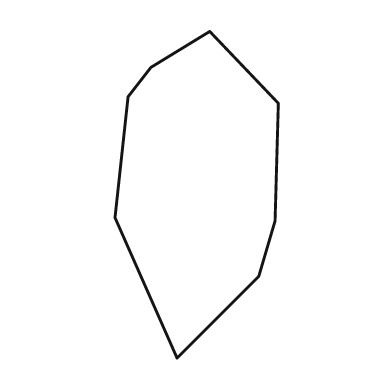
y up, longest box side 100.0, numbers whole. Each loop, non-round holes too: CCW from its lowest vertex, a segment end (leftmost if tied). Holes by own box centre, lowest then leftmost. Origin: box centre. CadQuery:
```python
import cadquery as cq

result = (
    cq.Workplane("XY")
    .moveTo(-6.0, -50.0)
    .lineTo(19.0, -25.0)
    .lineTo(24.0, -8.0)
    .lineTo(25.0, 28.0)
    .lineTo(4.0, 50.0)
    .lineTo(-14.0, 39.0)
    .lineTo(-21.0, 30.0)
    .lineTo(-25.0, -7.0)
    .close()
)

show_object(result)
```